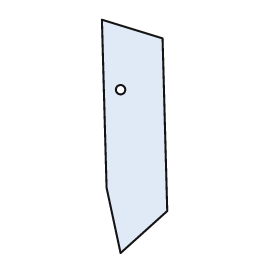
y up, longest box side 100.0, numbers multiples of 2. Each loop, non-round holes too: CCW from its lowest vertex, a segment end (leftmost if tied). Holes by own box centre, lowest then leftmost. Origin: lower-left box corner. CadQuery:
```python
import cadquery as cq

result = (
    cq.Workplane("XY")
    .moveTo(8.0, 0.0)
    .lineTo(28.0, 18.0)
    .lineTo(26.0, 92.0)
    .lineTo(0.0, 100.0)
    .lineTo(2.0, 28.0)
    .close()
    .moveTo(8.0, 70.0)
    .circle(2.0)
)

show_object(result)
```